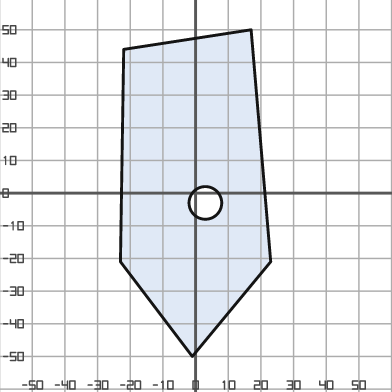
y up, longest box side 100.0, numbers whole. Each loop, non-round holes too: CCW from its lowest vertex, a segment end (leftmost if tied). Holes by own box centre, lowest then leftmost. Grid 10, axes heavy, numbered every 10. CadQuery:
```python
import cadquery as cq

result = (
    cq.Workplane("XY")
    .moveTo(-1.0, -50.0)
    .lineTo(23.0, -21.0)
    .lineTo(17.0, 50.0)
    .lineTo(-22.0, 44.0)
    .lineTo(-23.0, -21.0)
    .close()
    .moveTo(3.0, -3.0)
    .circle(5.0)
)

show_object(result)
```